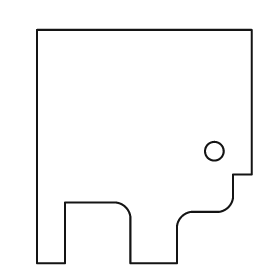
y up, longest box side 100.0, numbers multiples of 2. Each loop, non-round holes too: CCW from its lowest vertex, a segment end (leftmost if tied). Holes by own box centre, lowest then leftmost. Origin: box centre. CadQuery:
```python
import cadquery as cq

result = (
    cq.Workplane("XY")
    .moveTo(-46.0, -50.0)
    .lineTo(-34.0, -50.0)
    .lineTo(-34.0, -24.0)
    .lineTo(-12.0, -24.0)
    .threePointArc((-8.0, -26.0), (-6.0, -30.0))
    .lineTo(-6.0, -50.0)
    .lineTo(14.0, -50.0)
    .lineTo(14.0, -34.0)
    .threePointArc((16.0, -30.0), (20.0, -28.0))
    .lineTo(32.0, -28.0)
    .threePointArc((36.0, -26.0), (38.0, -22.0))
    .lineTo(38.0, -12.0)
    .lineTo(46.0, -12.0)
    .lineTo(46.0, 50.0)
    .lineTo(-46.0, 50.0)
    .close()
    .moveTo(30.0, -2.0)
    .circle(4.0)
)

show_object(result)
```